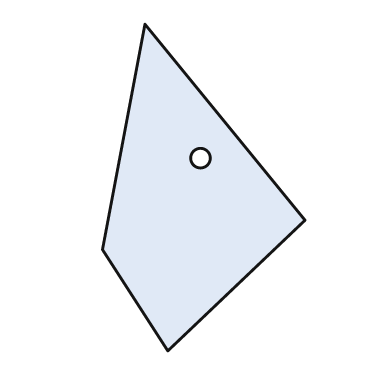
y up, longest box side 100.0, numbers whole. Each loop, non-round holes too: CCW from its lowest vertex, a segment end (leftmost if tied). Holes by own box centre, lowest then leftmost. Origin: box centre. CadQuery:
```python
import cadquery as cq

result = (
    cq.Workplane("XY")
    .moveTo(-11.0, -50.0)
    .lineTo(31.0, -10.0)
    .lineTo(-18.0, 50.0)
    .lineTo(-31.0, -19.0)
    .close()
    .moveTo(-1.0, 9.0)
    .circle(3.0)
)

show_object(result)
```